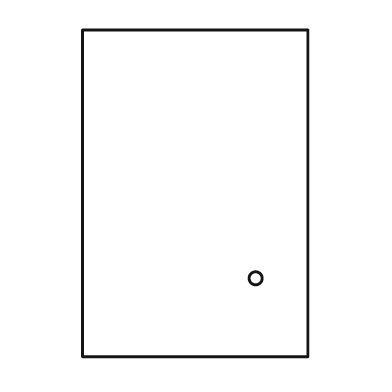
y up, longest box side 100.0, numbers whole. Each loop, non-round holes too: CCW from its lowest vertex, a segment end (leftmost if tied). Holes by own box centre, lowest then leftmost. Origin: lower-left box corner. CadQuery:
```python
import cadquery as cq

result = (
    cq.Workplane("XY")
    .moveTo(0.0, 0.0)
    .lineTo(69.0, 0.0)
    .lineTo(69.0, 100.0)
    .lineTo(0.0, 100.0)
    .close()
    .moveTo(53.0, 24.0)
    .circle(2.0)
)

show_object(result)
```